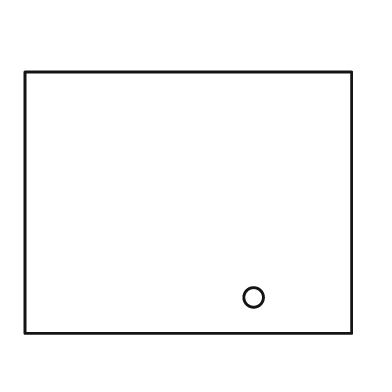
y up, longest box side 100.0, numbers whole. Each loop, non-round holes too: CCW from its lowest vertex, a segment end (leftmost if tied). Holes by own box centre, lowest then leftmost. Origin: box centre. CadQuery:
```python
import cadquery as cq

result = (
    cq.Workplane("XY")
    .moveTo(-50.0, -40.0)
    .lineTo(50.0, -40.0)
    .lineTo(50.0, 40.0)
    .lineTo(-50.0, 40.0)
    .close()
    .moveTo(20.0, -29.0)
    .circle(3.0)
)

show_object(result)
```